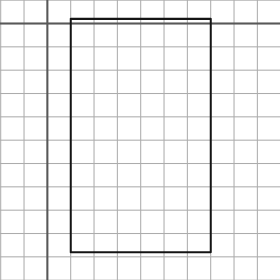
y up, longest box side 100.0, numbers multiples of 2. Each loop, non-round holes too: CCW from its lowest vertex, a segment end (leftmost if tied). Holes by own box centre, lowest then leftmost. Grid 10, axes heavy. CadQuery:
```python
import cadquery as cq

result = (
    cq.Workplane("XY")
    .moveTo(10.0, -98.0)
    .lineTo(70.0, -98.0)
    .lineTo(70.0, 2.0)
    .lineTo(10.0, 2.0)
    .close()
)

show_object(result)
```